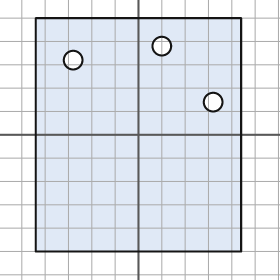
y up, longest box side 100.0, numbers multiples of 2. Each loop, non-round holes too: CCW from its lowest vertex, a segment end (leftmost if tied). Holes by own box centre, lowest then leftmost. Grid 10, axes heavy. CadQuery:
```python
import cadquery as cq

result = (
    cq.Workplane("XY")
    .moveTo(-44.0, -50.0)
    .lineTo(44.0, -50.0)
    .lineTo(44.0, 50.0)
    .lineTo(-44.0, 50.0)
    .close()
    .moveTo(32.0, 14.0)
    .circle(4.0)
    .moveTo(-28.0, 32.0)
    .circle(4.0)
    .moveTo(10.0, 38.0)
    .circle(4.0)
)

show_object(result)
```